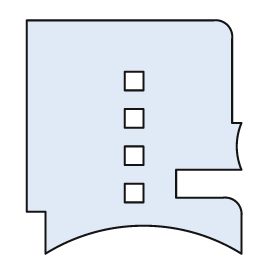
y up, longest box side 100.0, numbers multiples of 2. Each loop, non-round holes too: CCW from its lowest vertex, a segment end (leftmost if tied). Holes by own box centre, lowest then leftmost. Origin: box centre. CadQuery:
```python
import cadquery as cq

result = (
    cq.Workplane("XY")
    .moveTo(-38.0, -50.0)
    .threePointArc((4.0, -38.0), (46.0, -50.0))
    .lineTo(46.0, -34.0)
    .threePointArc((44.0, -28.0), (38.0, -26.0))
    .lineTo(18.0, -26.0)
    .lineTo(18.0, -14.0)
    .lineTo(46.0, -14.0)
    .threePointArc((44.0, -4.0), (46.0, 6.0))
    .lineTo(42.0, 6.0)
    .lineTo(42.0, 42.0)
    .threePointArc((40.0, 48.0), (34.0, 50.0))
    .lineTo(-46.0, 50.0)
    .lineTo(-46.0, -32.0)
    .lineTo(-38.0, -32.0)
    .close()
    .moveTo(-4.0, -28.0)
    .lineTo(4.0, -28.0)
    .lineTo(4.0, -20.0)
    .lineTo(-4.0, -20.0)
    .close()
    .moveTo(-4.0, -12.0)
    .lineTo(4.0, -12.0)
    .lineTo(4.0, -4.0)
    .lineTo(-4.0, -4.0)
    .close()
    .moveTo(-4.0, 4.0)
    .lineTo(4.0, 4.0)
    .lineTo(4.0, 12.0)
    .lineTo(-4.0, 12.0)
    .close()
    .moveTo(-4.0, 20.0)
    .lineTo(4.0, 20.0)
    .lineTo(4.0, 28.0)
    .lineTo(-4.0, 28.0)
    .close()
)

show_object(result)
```